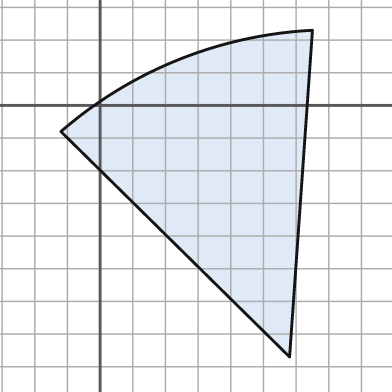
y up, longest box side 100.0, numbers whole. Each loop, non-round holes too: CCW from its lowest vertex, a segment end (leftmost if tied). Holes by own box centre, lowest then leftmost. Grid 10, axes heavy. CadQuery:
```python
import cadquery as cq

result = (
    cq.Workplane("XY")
    .moveTo(58.0, -77.0)
    .lineTo(65.0, 23.0)
    .threePointArc((24.0, 14.0), (-12.0, -8.0))
    .close()
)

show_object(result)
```